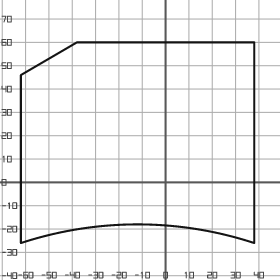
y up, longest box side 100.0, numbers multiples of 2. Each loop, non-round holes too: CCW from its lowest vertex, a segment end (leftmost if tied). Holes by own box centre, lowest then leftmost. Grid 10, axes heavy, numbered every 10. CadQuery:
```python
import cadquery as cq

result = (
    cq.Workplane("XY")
    .moveTo(-62.0, -26.0)
    .threePointArc((-12.0, -18.0), (38.0, -26.0))
    .lineTo(38.0, 60.0)
    .lineTo(-38.0, 60.0)
    .lineTo(-62.0, 46.0)
    .close()
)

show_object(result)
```